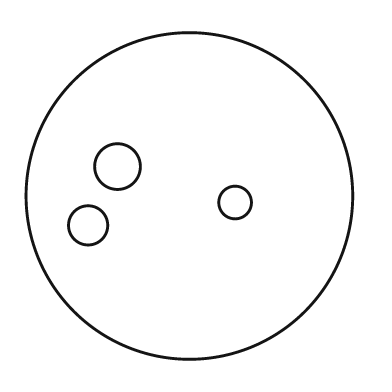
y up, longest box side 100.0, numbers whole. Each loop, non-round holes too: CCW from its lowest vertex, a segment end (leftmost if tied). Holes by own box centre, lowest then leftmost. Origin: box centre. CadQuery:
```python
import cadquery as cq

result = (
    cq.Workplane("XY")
    .moveTo(0.0, 0.0)
    .circle(50.0)
    .moveTo(-31.0, -9.0)
    .circle(6.0)
    .moveTo(14.0, -2.0)
    .circle(5.0)
    .moveTo(-22.0, 9.0)
    .circle(7.0)
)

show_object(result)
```